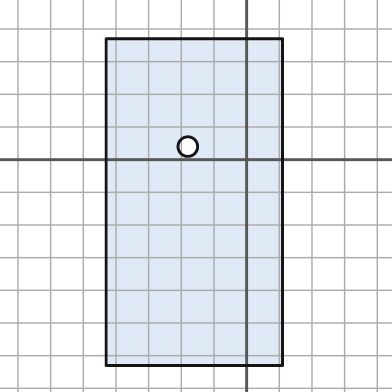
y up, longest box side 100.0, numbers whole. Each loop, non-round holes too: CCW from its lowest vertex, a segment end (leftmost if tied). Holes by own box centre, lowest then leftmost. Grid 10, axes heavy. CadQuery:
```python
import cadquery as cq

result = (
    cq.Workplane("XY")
    .moveTo(-43.0, -63.0)
    .lineTo(11.0, -63.0)
    .lineTo(11.0, 37.0)
    .lineTo(-43.0, 37.0)
    .close()
    .moveTo(-18.0, 4.0)
    .circle(3.0)
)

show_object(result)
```